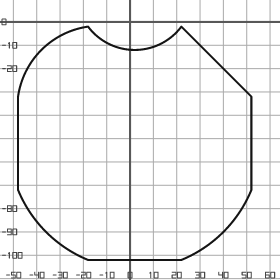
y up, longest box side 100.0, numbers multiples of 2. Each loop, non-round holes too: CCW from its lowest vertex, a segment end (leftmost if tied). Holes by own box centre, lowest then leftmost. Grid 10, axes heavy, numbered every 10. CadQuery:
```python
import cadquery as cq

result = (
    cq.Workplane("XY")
    .moveTo(-18.0, -102.0)
    .lineTo(22.0, -102.0)
    .threePointArc((40.0, -90.0), (52.0, -72.0))
    .lineTo(52.0, -32.0)
    .lineTo(22.0, -2.0)
    .threePointArc((2.0, -12.0), (-18.0, -2.0))
    .threePointArc((-38.0, -12.0), (-48.0, -32.0))
    .lineTo(-48.0, -72.0)
    .threePointArc((-36.0, -90.0), (-18.0, -102.0))
    .close()
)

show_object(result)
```